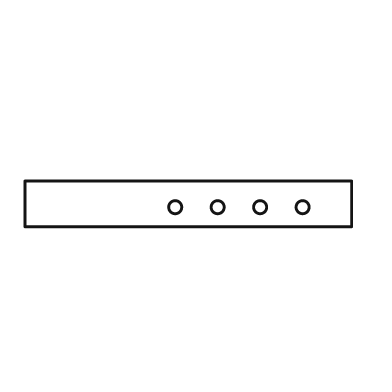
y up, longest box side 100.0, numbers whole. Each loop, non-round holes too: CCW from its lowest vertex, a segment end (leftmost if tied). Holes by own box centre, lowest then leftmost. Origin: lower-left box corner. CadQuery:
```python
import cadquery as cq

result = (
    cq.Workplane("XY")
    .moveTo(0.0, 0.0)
    .lineTo(100.0, 0.0)
    .lineTo(100.0, 14.0)
    .lineTo(0.0, 14.0)
    .close()
    .moveTo(46.0, 6.0)
    .circle(2.0)
    .moveTo(59.0, 6.0)
    .circle(2.0)
    .moveTo(72.0, 6.0)
    .circle(2.0)
    .moveTo(85.0, 6.0)
    .circle(2.0)
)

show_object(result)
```